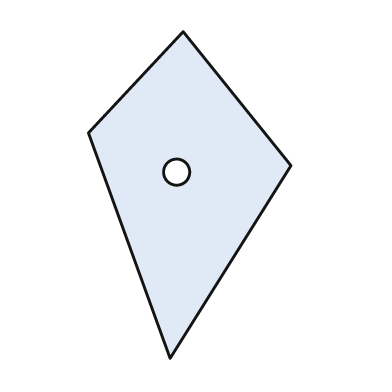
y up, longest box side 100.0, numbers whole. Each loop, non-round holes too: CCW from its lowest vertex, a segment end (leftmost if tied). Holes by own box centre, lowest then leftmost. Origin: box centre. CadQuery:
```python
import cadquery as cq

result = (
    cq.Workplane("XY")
    .moveTo(-6.0, -50.0)
    .lineTo(31.0, 9.0)
    .lineTo(-2.0, 50.0)
    .lineTo(-31.0, 19.0)
    .close()
    .moveTo(-4.0, 7.0)
    .circle(4.0)
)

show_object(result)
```